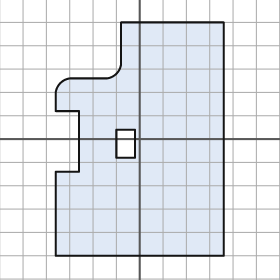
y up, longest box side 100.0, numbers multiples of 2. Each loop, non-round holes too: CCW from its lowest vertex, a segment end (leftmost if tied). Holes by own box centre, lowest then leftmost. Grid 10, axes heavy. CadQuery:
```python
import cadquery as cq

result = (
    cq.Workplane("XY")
    .moveTo(-36.0, -50.0)
    .lineTo(36.0, -50.0)
    .lineTo(36.0, 50.0)
    .lineTo(-8.0, 50.0)
    .lineTo(-8.0, 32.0)
    .threePointArc((-10.0, 28.0), (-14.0, 26.0))
    .lineTo(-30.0, 26.0)
    .threePointArc((-34.0, 24.0), (-36.0, 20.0))
    .lineTo(-36.0, 12.0)
    .lineTo(-26.0, 12.0)
    .lineTo(-26.0, -14.0)
    .lineTo(-36.0, -14.0)
    .close()
    .moveTo(-10.0, -8.0)
    .lineTo(-2.0, -8.0)
    .lineTo(-2.0, 4.0)
    .lineTo(-10.0, 4.0)
    .close()
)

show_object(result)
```